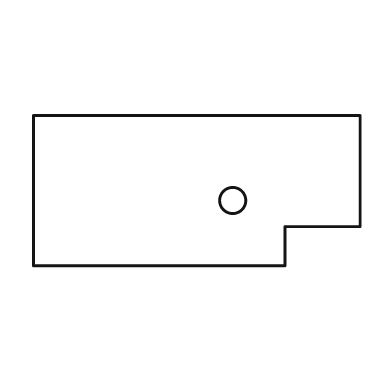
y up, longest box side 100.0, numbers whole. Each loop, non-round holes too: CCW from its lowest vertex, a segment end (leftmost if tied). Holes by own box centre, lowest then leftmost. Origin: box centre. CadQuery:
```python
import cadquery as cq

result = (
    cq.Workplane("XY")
    .moveTo(-50.0, -23.0)
    .lineTo(27.0, -23.0)
    .lineTo(27.0, -11.0)
    .lineTo(50.0, -11.0)
    .lineTo(50.0, 23.0)
    .lineTo(-50.0, 23.0)
    .close()
    .moveTo(11.0, -3.0)
    .circle(4.0)
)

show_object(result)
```